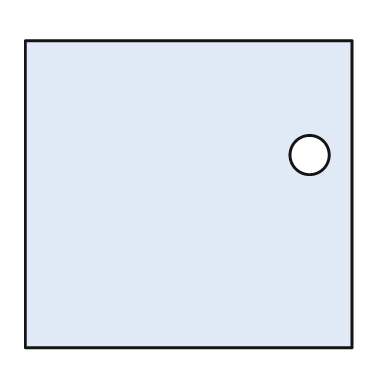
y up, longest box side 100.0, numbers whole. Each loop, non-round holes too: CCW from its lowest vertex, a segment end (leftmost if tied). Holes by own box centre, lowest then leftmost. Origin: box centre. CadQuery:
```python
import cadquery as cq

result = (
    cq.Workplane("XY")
    .moveTo(-50.0, -47.0)
    .lineTo(50.0, -47.0)
    .lineTo(50.0, 47.0)
    .lineTo(-50.0, 47.0)
    .close()
    .moveTo(37.0, 12.0)
    .circle(6.0)
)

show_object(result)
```